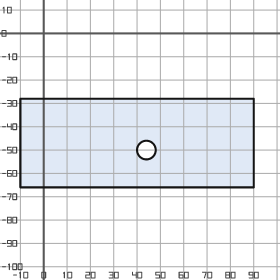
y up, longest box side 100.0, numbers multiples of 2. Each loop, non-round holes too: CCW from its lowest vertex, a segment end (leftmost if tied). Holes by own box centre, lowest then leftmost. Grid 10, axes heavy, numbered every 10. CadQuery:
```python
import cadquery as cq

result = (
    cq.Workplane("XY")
    .moveTo(-10.0, -66.0)
    .lineTo(90.0, -66.0)
    .lineTo(90.0, -28.0)
    .lineTo(-10.0, -28.0)
    .close()
    .moveTo(44.0, -50.0)
    .circle(4.0)
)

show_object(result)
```